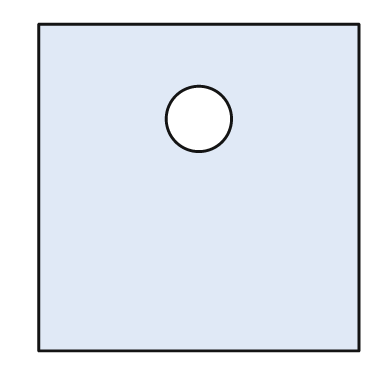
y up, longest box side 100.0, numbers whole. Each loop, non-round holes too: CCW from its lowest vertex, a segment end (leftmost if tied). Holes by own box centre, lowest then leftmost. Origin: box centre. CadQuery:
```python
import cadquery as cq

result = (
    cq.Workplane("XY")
    .moveTo(-49.0, -50.0)
    .lineTo(49.0, -50.0)
    .lineTo(49.0, 50.0)
    .lineTo(-49.0, 50.0)
    .close()
    .moveTo(0.0, 21.0)
    .circle(10.0)
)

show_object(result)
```